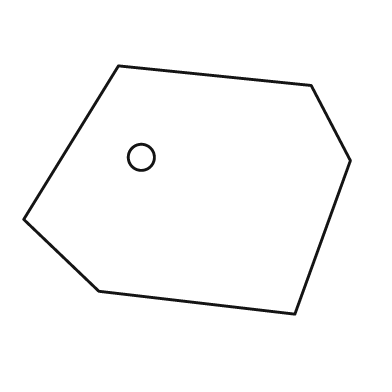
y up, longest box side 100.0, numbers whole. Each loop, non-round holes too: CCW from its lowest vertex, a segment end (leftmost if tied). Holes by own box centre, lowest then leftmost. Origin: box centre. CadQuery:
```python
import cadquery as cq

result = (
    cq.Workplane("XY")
    .moveTo(33.0, -38.0)
    .lineTo(50.0, 9.0)
    .lineTo(38.0, 32.0)
    .lineTo(-21.0, 38.0)
    .lineTo(-50.0, -9.0)
    .lineTo(-27.0, -31.0)
    .close()
    .moveTo(-14.0, 10.0)
    .circle(4.0)
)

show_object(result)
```